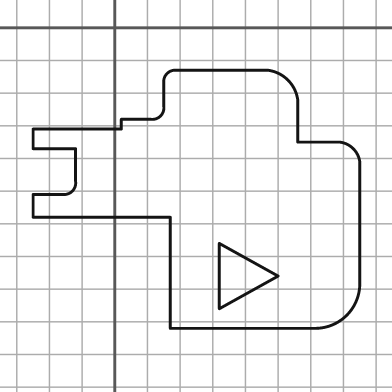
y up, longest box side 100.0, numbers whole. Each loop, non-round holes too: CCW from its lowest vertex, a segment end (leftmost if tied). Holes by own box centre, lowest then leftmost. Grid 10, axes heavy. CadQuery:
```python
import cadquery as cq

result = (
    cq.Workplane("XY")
    .moveTo(17.0, -92.0)
    .lineTo(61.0, -92.0)
    .threePointArc((71.0, -88.0), (75.0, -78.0))
    .lineTo(75.0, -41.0)
    .threePointArc((73.0, -37.0), (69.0, -35.0))
    .lineTo(56.0, -35.0)
    .lineTo(56.0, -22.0)
    .threePointArc((53.0, -16.0), (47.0, -13.0))
    .lineTo(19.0, -13.0)
    .threePointArc((16.0, -14.0), (15.0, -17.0))
    .lineTo(15.0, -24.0)
    .threePointArc((14.0, -27.0), (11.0, -28.0))
    .lineTo(2.0, -28.0)
    .lineTo(2.0, -31.0)
    .lineTo(-25.0, -31.0)
    .lineTo(-25.0, -37.0)
    .lineTo(-12.0, -37.0)
    .lineTo(-12.0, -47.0)
    .threePointArc((-13.0, -50.0), (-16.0, -51.0))
    .lineTo(-25.0, -51.0)
    .lineTo(-25.0, -58.0)
    .lineTo(17.0, -58.0)
    .close()
    .moveTo(32.0, -86.0)
    .lineTo(50.0, -76.0)
    .lineTo(32.0, -66.0)
    .close()
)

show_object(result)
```